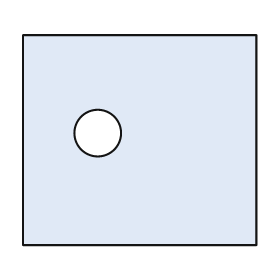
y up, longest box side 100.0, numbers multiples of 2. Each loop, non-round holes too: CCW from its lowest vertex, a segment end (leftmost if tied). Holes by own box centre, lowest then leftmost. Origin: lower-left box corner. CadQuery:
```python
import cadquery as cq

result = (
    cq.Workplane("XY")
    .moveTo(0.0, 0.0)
    .lineTo(100.0, 0.0)
    .lineTo(100.0, 90.0)
    .lineTo(0.0, 90.0)
    .close()
    .moveTo(32.0, 48.0)
    .circle(10.0)
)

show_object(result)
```